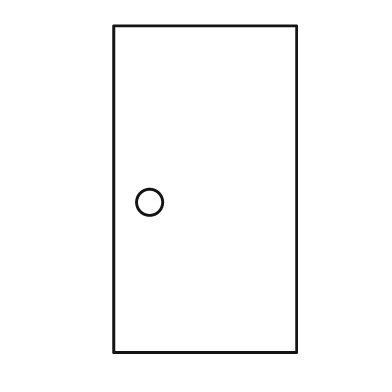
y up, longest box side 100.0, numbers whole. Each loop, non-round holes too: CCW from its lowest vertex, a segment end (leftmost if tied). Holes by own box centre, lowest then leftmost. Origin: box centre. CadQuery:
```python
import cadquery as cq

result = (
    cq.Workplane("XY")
    .moveTo(-28.0, -50.0)
    .lineTo(28.0, -50.0)
    .lineTo(28.0, 50.0)
    .lineTo(-28.0, 50.0)
    .close()
    .moveTo(-17.0, -4.0)
    .circle(4.0)
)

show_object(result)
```